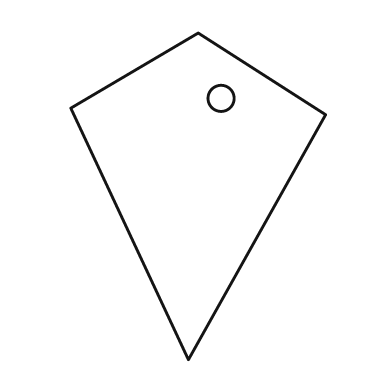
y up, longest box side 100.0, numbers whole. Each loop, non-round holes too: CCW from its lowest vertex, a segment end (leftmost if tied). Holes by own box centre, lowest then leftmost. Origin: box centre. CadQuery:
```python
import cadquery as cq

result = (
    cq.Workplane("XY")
    .moveTo(-3.0, -50.0)
    .lineTo(39.0, 25.0)
    .lineTo(0.0, 50.0)
    .lineTo(-39.0, 27.0)
    .close()
    .moveTo(7.0, 30.0)
    .circle(4.0)
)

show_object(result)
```